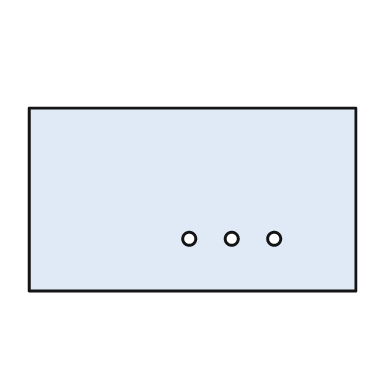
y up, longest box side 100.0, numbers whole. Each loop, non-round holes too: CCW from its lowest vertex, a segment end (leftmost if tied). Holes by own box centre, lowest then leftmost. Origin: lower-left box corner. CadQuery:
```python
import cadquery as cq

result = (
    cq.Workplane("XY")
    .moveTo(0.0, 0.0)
    .lineTo(100.0, 0.0)
    .lineTo(100.0, 56.0)
    .lineTo(0.0, 56.0)
    .close()
    .moveTo(49.0, 16.0)
    .circle(2.0)
    .moveTo(62.0, 16.0)
    .circle(2.0)
    .moveTo(75.0, 16.0)
    .circle(2.0)
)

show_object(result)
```